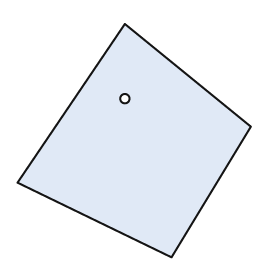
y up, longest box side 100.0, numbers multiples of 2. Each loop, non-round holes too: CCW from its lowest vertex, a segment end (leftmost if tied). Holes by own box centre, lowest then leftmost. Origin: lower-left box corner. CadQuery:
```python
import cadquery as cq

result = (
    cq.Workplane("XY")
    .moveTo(66.0, 0.0)
    .lineTo(100.0, 56.0)
    .lineTo(46.0, 100.0)
    .lineTo(0.0, 32.0)
    .close()
    .moveTo(46.0, 68.0)
    .circle(2.0)
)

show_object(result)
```